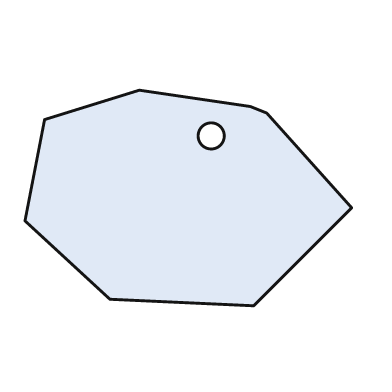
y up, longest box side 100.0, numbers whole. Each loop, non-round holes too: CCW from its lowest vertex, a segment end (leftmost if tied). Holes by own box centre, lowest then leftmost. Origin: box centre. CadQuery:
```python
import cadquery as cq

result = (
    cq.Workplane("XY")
    .moveTo(20.0, -33.0)
    .lineTo(50.0, -3.0)
    .lineTo(24.0, 26.0)
    .lineTo(19.0, 28.0)
    .lineTo(-15.0, 33.0)
    .lineTo(-44.0, 24.0)
    .lineTo(-50.0, -7.0)
    .lineTo(-24.0, -31.0)
    .close()
    .moveTo(7.0, 19.0)
    .circle(4.0)
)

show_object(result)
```